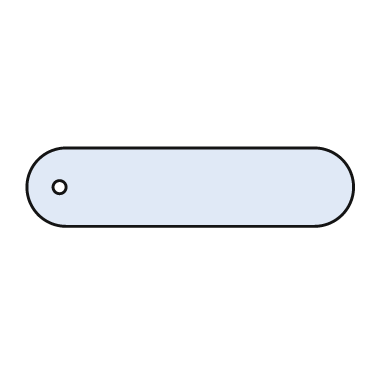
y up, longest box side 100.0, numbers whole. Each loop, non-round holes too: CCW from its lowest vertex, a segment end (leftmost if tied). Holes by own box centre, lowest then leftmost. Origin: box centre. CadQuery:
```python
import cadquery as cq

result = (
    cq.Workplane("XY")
    .moveTo(-38.0, -12.0)
    .lineTo(38.0, -12.0)
    .threePointArc((50.0, 0.0), (38.0, 12.0))
    .lineTo(-38.0, 12.0)
    .threePointArc((-50.0, 0.0), (-38.0, -12.0))
    .close()
    .moveTo(-40.0, 0.0)
    .circle(2.0)
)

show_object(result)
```